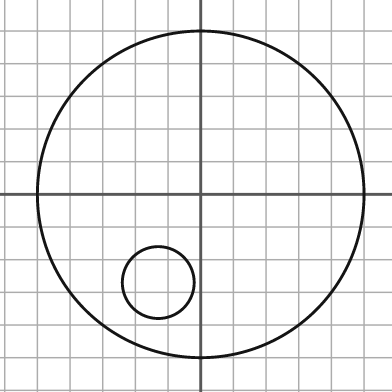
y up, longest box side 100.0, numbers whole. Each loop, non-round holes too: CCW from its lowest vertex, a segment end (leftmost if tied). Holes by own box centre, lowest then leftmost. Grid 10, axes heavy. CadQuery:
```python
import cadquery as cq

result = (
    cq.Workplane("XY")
    .moveTo(0.0, 0.0)
    .circle(50.0)
    .moveTo(-13.0, -27.0)
    .circle(11.0)
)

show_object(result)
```